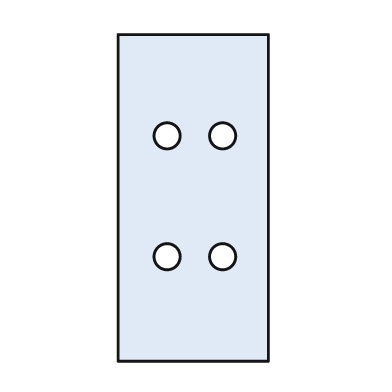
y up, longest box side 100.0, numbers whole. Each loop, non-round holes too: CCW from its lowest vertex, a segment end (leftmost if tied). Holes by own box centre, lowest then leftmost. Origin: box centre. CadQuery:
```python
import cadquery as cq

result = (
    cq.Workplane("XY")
    .moveTo(-23.0, -50.0)
    .lineTo(23.0, -50.0)
    .lineTo(23.0, 50.0)
    .lineTo(-23.0, 50.0)
    .close()
    .moveTo(-8.0, -18.0)
    .circle(4.0)
    .moveTo(9.0, -18.0)
    .circle(4.0)
    .moveTo(-8.0, 19.0)
    .circle(4.0)
    .moveTo(9.0, 19.0)
    .circle(4.0)
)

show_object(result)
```